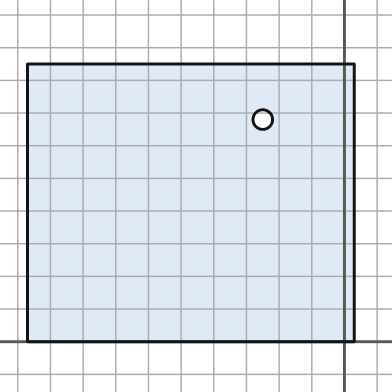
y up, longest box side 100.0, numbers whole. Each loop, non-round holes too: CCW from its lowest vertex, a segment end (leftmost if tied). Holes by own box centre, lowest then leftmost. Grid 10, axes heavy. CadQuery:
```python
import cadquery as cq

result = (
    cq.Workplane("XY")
    .moveTo(-97.0, 0.0)
    .lineTo(3.0, 0.0)
    .lineTo(3.0, 85.0)
    .lineTo(-97.0, 85.0)
    .close()
    .moveTo(-25.0, 68.0)
    .circle(3.0)
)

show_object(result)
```